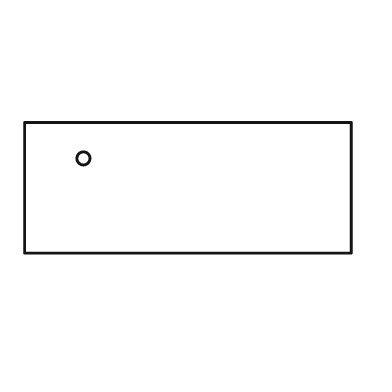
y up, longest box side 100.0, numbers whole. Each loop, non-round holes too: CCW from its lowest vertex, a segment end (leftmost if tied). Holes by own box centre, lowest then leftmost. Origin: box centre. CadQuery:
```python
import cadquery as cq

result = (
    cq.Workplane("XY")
    .moveTo(-50.0, -20.0)
    .lineTo(50.0, -20.0)
    .lineTo(50.0, 20.0)
    .lineTo(-50.0, 20.0)
    .close()
    .moveTo(-32.0, 9.0)
    .circle(2.0)
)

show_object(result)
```